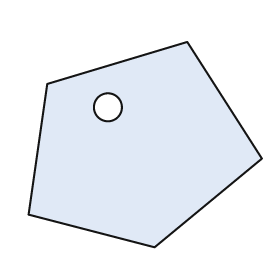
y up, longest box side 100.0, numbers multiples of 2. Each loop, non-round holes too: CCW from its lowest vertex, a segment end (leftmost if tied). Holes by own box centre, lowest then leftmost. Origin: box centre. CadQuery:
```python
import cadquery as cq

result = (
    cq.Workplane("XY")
    .moveTo(4.0, -44.0)
    .lineTo(50.0, -6.0)
    .lineTo(18.0, 44.0)
    .lineTo(-42.0, 26.0)
    .lineTo(-50.0, -30.0)
    .close()
    .moveTo(-16.0, 16.0)
    .circle(6.0)
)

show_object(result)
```